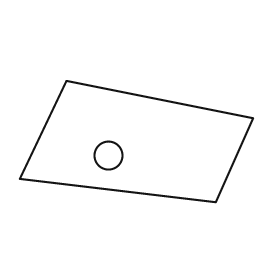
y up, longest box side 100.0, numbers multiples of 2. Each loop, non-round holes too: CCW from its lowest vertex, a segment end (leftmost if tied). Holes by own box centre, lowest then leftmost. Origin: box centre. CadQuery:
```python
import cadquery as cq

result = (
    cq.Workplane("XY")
    .moveTo(34.0, -26.0)
    .lineTo(50.0, 10.0)
    .lineTo(-30.0, 26.0)
    .lineTo(-50.0, -16.0)
    .close()
    .moveTo(-12.0, -6.0)
    .circle(6.0)
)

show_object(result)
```